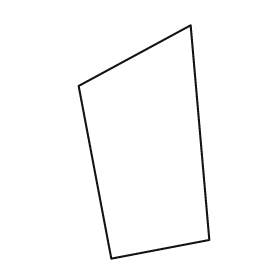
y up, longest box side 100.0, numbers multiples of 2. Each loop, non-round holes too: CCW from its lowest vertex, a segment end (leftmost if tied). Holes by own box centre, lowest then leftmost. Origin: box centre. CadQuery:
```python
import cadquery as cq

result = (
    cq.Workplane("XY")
    .moveTo(-14.0, -50.0)
    .lineTo(28.0, -42.0)
    .lineTo(20.0, 50.0)
    .lineTo(-28.0, 24.0)
    .close()
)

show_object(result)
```